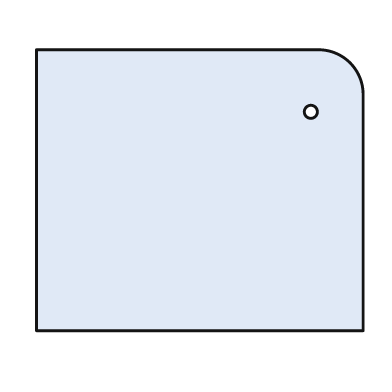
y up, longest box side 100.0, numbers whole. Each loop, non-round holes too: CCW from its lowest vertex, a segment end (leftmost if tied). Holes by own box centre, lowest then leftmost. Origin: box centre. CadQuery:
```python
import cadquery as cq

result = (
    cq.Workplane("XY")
    .moveTo(-50.0, -43.0)
    .lineTo(50.0, -43.0)
    .lineTo(50.0, 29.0)
    .threePointArc((46.0, 39.0), (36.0, 43.0))
    .lineTo(-50.0, 43.0)
    .close()
    .moveTo(34.0, 24.0)
    .circle(2.0)
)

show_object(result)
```